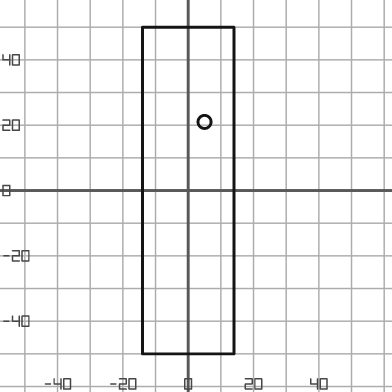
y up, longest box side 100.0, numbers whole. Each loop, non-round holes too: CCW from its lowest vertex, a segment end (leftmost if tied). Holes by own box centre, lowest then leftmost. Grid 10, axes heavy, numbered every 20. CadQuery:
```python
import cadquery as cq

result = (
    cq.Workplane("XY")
    .moveTo(-14.0, -50.0)
    .lineTo(14.0, -50.0)
    .lineTo(14.0, 50.0)
    .lineTo(-14.0, 50.0)
    .close()
    .moveTo(5.0, 21.0)
    .circle(2.0)
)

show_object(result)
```